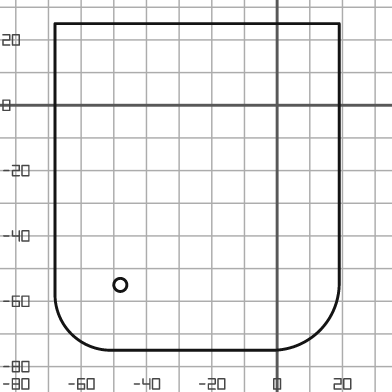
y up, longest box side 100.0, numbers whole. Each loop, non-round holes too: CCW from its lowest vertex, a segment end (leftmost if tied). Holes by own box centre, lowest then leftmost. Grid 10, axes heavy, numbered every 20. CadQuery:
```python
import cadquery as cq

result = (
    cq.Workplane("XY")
    .moveTo(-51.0, -75.0)
    .lineTo(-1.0, -75.0)
    .threePointArc((13.0, -69.0), (19.0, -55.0))
    .lineTo(19.0, 25.0)
    .lineTo(-68.0, 25.0)
    .lineTo(-68.0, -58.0)
    .threePointArc((-63.0, -70.0), (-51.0, -75.0))
    .close()
    .moveTo(-48.0, -55.0)
    .circle(2.0)
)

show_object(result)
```